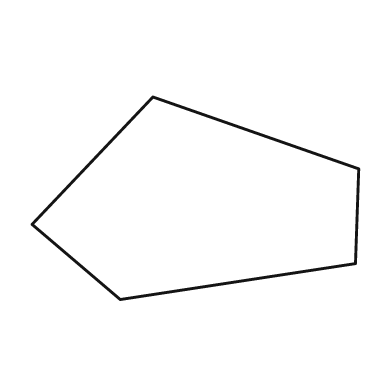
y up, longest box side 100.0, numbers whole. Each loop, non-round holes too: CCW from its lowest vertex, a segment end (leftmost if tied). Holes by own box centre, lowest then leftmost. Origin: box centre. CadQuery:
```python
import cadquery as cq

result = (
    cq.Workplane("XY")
    .moveTo(-23.0, -31.0)
    .lineTo(49.0, -20.0)
    .lineTo(50.0, 9.0)
    .lineTo(-13.0, 31.0)
    .lineTo(-50.0, -8.0)
    .close()
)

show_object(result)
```